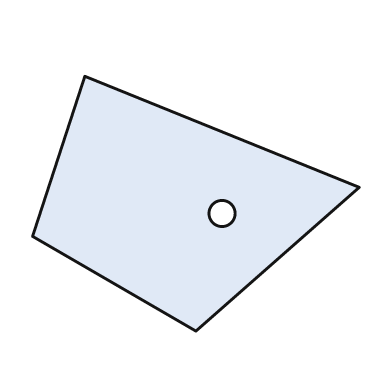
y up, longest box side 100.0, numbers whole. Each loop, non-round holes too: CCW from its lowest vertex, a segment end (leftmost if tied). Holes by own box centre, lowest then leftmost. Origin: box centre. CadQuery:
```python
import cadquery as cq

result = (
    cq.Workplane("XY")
    .moveTo(0.0, -39.0)
    .lineTo(50.0, 5.0)
    .lineTo(-34.0, 39.0)
    .lineTo(-50.0, -10.0)
    .close()
    .moveTo(8.0, -3.0)
    .circle(4.0)
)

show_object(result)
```